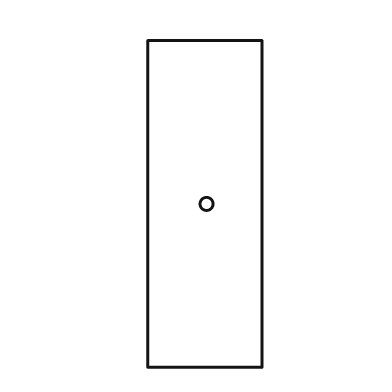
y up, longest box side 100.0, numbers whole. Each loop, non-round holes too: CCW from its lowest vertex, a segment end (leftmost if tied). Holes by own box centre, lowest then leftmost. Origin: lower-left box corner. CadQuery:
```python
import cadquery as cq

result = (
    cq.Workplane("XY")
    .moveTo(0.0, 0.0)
    .lineTo(35.0, 0.0)
    .lineTo(35.0, 100.0)
    .lineTo(0.0, 100.0)
    .close()
    .moveTo(18.0, 50.0)
    .circle(2.0)
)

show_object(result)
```